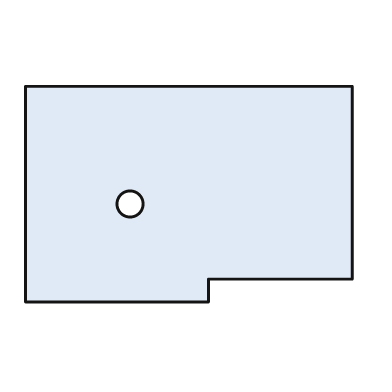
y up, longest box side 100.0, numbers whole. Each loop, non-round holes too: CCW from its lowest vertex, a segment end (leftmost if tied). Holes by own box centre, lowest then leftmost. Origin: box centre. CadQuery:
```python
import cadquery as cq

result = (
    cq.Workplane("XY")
    .moveTo(-50.0, -33.0)
    .lineTo(6.0, -33.0)
    .lineTo(6.0, -26.0)
    .lineTo(50.0, -26.0)
    .lineTo(50.0, 33.0)
    .lineTo(-50.0, 33.0)
    .close()
    .moveTo(-18.0, -3.0)
    .circle(4.0)
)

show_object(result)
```